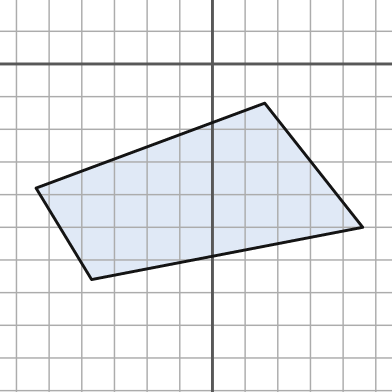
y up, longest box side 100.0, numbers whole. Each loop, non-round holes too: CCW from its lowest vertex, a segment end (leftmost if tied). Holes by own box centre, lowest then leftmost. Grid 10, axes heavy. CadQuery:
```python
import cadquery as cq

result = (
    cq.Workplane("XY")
    .moveTo(-37.0, -66.0)
    .lineTo(46.0, -50.0)
    .lineTo(16.0, -12.0)
    .lineTo(-54.0, -38.0)
    .close()
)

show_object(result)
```